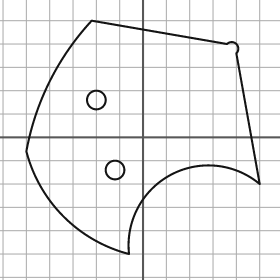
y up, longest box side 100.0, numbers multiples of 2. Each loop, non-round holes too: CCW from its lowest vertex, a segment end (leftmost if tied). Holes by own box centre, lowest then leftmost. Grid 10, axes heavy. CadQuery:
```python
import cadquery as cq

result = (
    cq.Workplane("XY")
    .moveTo(-6.0, -50.0)
    .threePointArc((12.0, -16.0), (50.0, -20.0))
    .lineTo(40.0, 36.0)
    .threePointArc((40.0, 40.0), (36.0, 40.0))
    .lineTo(-22.0, 50.0)
    .threePointArc((-40.0, 24.0), (-50.0, -6.0))
    .threePointArc((-34.0, -34.0), (-6.0, -50.0))
    .close()
    .moveTo(-12.0, -14.0)
    .circle(4.0)
    .moveTo(-20.0, 16.0)
    .circle(4.0)
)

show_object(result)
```